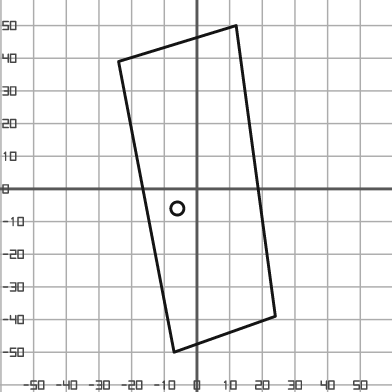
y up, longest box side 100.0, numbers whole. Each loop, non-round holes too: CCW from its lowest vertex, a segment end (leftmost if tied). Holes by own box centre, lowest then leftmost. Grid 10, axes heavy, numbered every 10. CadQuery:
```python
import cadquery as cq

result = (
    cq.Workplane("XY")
    .moveTo(-7.0, -50.0)
    .lineTo(24.0, -39.0)
    .lineTo(12.0, 50.0)
    .lineTo(-24.0, 39.0)
    .close()
    .moveTo(-6.0, -6.0)
    .circle(2.0)
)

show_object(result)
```